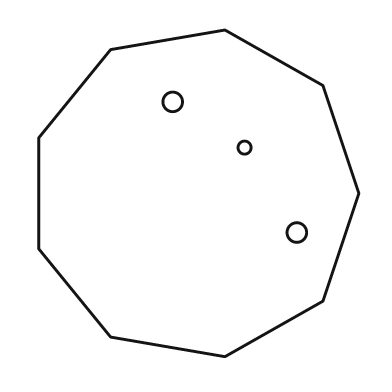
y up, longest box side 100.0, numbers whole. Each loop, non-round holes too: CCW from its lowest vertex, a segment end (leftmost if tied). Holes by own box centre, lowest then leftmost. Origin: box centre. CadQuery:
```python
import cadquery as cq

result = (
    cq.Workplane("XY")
    .moveTo(8.0, -50.0)
    .lineTo(38.0, -33.0)
    .lineTo(49.0, 0.0)
    .lineTo(38.0, 33.0)
    .lineTo(8.0, 50.0)
    .lineTo(-27.0, 44.0)
    .lineTo(-49.0, 17.0)
    .lineTo(-49.0, -17.0)
    .lineTo(-27.0, -44.0)
    .close()
    .moveTo(30.0, -12.0)
    .circle(3.0)
    .moveTo(14.0, 14.0)
    .circle(2.0)
    .moveTo(-8.0, 28.0)
    .circle(3.0)
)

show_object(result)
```